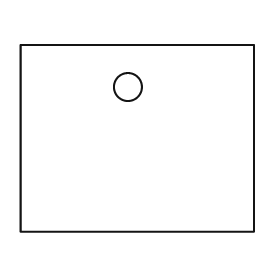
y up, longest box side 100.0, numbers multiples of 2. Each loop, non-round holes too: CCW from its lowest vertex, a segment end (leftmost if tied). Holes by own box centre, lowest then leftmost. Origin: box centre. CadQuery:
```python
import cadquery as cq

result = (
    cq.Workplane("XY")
    .moveTo(-50.0, -40.0)
    .lineTo(50.0, -40.0)
    .lineTo(50.0, 40.0)
    .lineTo(-50.0, 40.0)
    .close()
    .moveTo(-4.0, 22.0)
    .circle(6.0)
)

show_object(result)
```